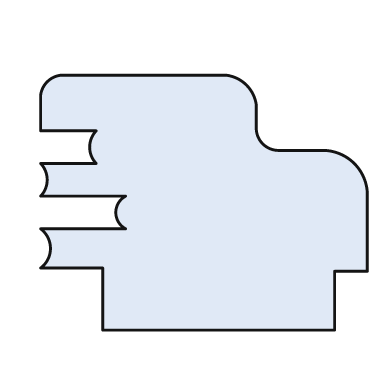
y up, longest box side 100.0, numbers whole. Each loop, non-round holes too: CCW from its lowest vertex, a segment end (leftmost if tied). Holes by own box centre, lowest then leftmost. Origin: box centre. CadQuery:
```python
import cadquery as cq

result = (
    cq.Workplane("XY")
    .moveTo(-31.0, -39.0)
    .lineTo(40.0, -39.0)
    .lineTo(40.0, -21.0)
    .lineTo(50.0, -21.0)
    .lineTo(50.0, 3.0)
    .threePointArc((46.0, 12.0), (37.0, 16.0))
    .lineTo(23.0, 16.0)
    .threePointArc((18.0, 18.0), (16.0, 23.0))
    .lineTo(16.0, 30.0)
    .threePointArc((13.0, 36.0), (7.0, 39.0))
    .lineTo(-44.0, 39.0)
    .threePointArc((-48.0, 37.0), (-50.0, 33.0))
    .lineTo(-50.0, 22.0)
    .lineTo(-33.0, 22.0)
    .threePointArc((-35.0, 17.0), (-33.0, 12.0))
    .lineTo(-50.0, 12.0)
    .threePointArc((-48.0, 7.0), (-50.0, 2.0))
    .lineTo(-24.0, 2.0)
    .threePointArc((-27.0, -3.0), (-24.0, -8.0))
    .lineTo(-50.0, -8.0)
    .threePointArc((-47.0, -14.0), (-50.0, -20.0))
    .lineTo(-31.0, -20.0)
    .close()
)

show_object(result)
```